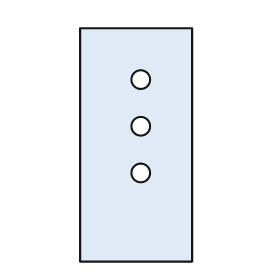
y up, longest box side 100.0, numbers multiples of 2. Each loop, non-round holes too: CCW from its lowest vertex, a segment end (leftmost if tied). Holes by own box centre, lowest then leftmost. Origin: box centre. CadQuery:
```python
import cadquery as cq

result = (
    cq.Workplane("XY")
    .moveTo(-24.0, -50.0)
    .lineTo(24.0, -50.0)
    .lineTo(24.0, 50.0)
    .lineTo(-24.0, 50.0)
    .close()
    .moveTo(2.0, -12.0)
    .circle(4.0)
    .moveTo(2.0, 8.0)
    .circle(4.0)
    .moveTo(2.0, 28.0)
    .circle(4.0)
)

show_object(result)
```